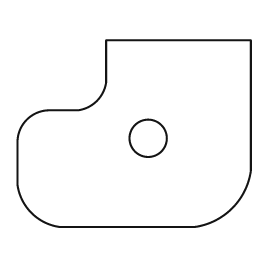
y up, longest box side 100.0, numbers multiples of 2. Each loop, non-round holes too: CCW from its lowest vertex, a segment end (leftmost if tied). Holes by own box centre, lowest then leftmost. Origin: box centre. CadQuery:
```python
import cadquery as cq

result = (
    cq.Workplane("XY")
    .moveTo(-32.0, -40.0)
    .lineTo(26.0, -40.0)
    .threePointArc((42.0, -32.0), (50.0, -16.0))
    .lineTo(50.0, 40.0)
    .lineTo(-12.0, 40.0)
    .lineTo(-12.0, 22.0)
    .threePointArc((-16.0, 14.0), (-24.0, 10.0))
    .lineTo(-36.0, 10.0)
    .threePointArc((-46.0, 6.0), (-50.0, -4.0))
    .lineTo(-50.0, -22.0)
    .threePointArc((-44.0, -34.0), (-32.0, -40.0))
    .close()
    .moveTo(6.0, -2.0)
    .circle(8.0)
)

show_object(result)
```